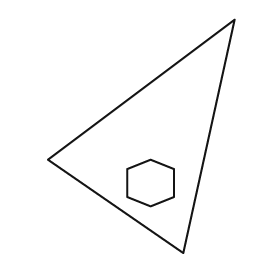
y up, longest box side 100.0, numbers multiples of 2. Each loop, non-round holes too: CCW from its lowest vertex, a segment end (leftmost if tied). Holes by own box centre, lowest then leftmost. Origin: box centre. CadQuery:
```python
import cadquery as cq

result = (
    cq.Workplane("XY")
    .moveTo(18.0, -50.0)
    .lineTo(40.0, 50.0)
    .lineTo(-40.0, -10.0)
    .close()
    .moveTo(4.0, -30.0)
    .lineTo(14.0, -26.0)
    .lineTo(14.0, -14.0)
    .lineTo(4.0, -10.0)
    .lineTo(-6.0, -14.0)
    .lineTo(-6.0, -26.0)
    .close()
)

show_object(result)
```